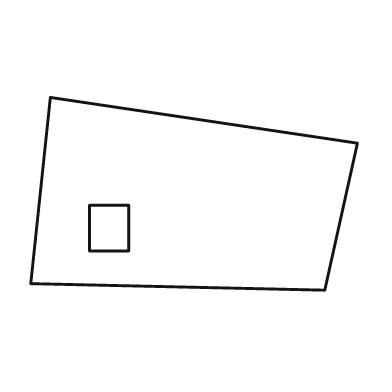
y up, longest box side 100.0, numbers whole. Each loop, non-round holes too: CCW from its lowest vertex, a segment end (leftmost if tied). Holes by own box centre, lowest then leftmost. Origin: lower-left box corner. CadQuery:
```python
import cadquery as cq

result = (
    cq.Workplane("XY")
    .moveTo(90.0, 0.0)
    .lineTo(100.0, 45.0)
    .lineTo(6.0, 59.0)
    .lineTo(0.0, 2.0)
    .close()
    .moveTo(18.0, 12.0)
    .lineTo(30.0, 12.0)
    .lineTo(30.0, 26.0)
    .lineTo(18.0, 26.0)
    .close()
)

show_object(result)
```